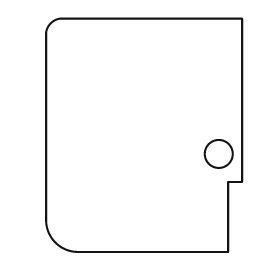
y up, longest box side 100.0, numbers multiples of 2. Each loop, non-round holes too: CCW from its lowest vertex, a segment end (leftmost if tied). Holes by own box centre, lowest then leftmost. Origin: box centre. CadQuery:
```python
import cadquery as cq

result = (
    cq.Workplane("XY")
    .moveTo(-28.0, -50.0)
    .lineTo(36.0, -50.0)
    .lineTo(36.0, -20.0)
    .lineTo(42.0, -20.0)
    .lineTo(42.0, 50.0)
    .lineTo(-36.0, 50.0)
    .threePointArc((-40.0, 48.0), (-42.0, 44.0))
    .lineTo(-42.0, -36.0)
    .threePointArc((-38.0, -46.0), (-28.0, -50.0))
    .close()
    .moveTo(32.0, -8.0)
    .circle(6.0)
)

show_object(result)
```